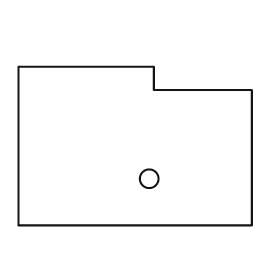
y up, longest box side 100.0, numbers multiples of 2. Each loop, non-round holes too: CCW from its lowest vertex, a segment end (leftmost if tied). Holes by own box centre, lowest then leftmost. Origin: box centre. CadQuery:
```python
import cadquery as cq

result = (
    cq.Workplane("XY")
    .moveTo(-50.0, -34.0)
    .lineTo(50.0, -34.0)
    .lineTo(50.0, 24.0)
    .lineTo(8.0, 24.0)
    .lineTo(8.0, 34.0)
    .lineTo(-50.0, 34.0)
    .close()
    .moveTo(6.0, -14.0)
    .circle(4.0)
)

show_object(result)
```